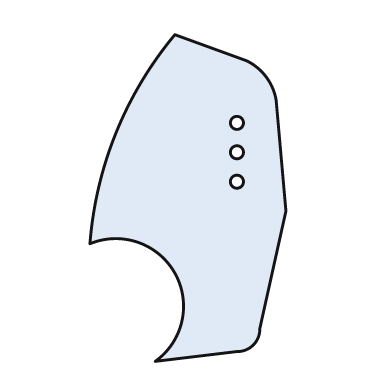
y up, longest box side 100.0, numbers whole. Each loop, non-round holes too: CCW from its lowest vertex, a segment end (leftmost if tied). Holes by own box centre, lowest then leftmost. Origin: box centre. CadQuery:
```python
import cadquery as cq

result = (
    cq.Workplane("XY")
    .moveTo(-10.0, -50.0)
    .lineTo(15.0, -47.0)
    .threePointArc((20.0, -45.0), (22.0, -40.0))
    .lineTo(30.0, -4.0)
    .lineTo(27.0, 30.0)
    .threePointArc((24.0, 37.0), (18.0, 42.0))
    .lineTo(-4.0, 50.0)
    .threePointArc((-22.0, 20.0), (-30.0, -14.0))
    .threePointArc((-4.0, -23.0), (-10.0, -50.0))
    .close()
    .moveTo(15.0, 5.0)
    .circle(2.0)
    .moveTo(15.0, 14.0)
    .circle(2.0)
    .moveTo(15.0, 23.0)
    .circle(2.0)
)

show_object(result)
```